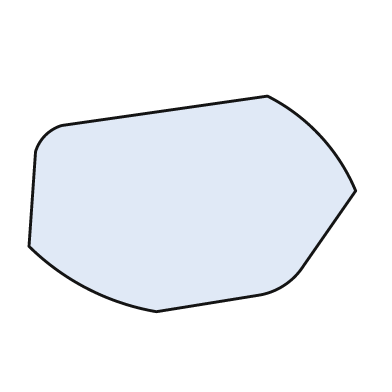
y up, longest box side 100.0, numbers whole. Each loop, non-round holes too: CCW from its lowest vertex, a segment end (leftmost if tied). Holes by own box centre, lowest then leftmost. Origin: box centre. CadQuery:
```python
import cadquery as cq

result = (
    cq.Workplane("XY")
    .moveTo(-11.0, -33.0)
    .lineTo(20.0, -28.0)
    .threePointArc((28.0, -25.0), (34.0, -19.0))
    .lineTo(50.0, 4.0)
    .threePointArc((39.0, 21.0), (23.0, 33.0))
    .lineTo(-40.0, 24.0)
    .threePointArc((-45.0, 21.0), (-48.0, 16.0))
    .lineTo(-50.0, -13.0)
    .threePointArc((-32.0, -26.0), (-11.0, -33.0))
    .close()
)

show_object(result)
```